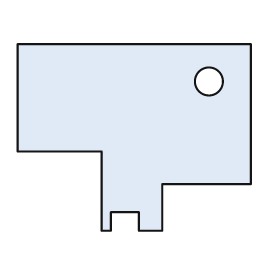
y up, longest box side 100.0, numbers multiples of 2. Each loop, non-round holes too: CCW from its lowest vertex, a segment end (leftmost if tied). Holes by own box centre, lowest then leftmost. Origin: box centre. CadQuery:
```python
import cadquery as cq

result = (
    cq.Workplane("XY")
    .moveTo(-14.0, -40.0)
    .lineTo(-10.0, -40.0)
    .lineTo(-10.0, -32.0)
    .lineTo(2.0, -32.0)
    .lineTo(2.0, -40.0)
    .lineTo(12.0, -40.0)
    .lineTo(12.0, -20.0)
    .lineTo(50.0, -20.0)
    .lineTo(50.0, 40.0)
    .lineTo(-50.0, 40.0)
    .lineTo(-50.0, -6.0)
    .lineTo(-14.0, -6.0)
    .close()
    .moveTo(32.0, 24.0)
    .circle(6.0)
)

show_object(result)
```